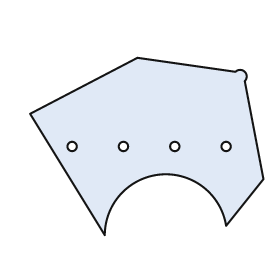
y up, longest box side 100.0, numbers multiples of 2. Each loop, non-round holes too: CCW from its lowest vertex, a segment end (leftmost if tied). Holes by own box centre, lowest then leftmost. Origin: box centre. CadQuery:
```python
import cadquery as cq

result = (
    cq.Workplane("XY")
    .moveTo(-18.0, -38.0)
    .threePointArc((6.0, -12.0), (34.0, -34.0))
    .lineTo(50.0, -14.0)
    .lineTo(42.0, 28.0)
    .threePointArc((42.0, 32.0), (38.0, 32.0))
    .lineTo(-4.0, 38.0)
    .lineTo(-50.0, 14.0)
    .close()
    .moveTo(-32.0, 0.0)
    .circle(2.0)
    .moveTo(-10.0, 0.0)
    .circle(2.0)
    .moveTo(12.0, 0.0)
    .circle(2.0)
    .moveTo(34.0, 0.0)
    .circle(2.0)
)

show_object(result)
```